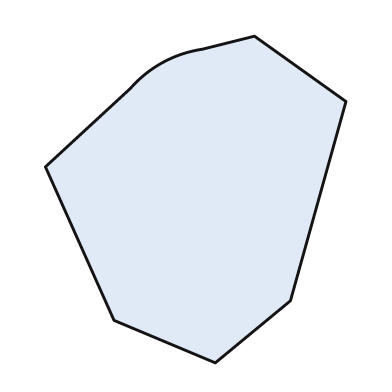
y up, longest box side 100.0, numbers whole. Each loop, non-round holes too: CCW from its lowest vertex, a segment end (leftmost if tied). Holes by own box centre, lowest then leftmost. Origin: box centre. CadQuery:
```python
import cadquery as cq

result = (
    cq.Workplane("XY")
    .moveTo(6.0, -50.0)
    .lineTo(29.0, -31.0)
    .lineTo(46.0, 30.0)
    .lineTo(18.0, 50.0)
    .lineTo(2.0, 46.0)
    .threePointArc((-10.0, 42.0), (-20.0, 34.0))
    .lineTo(-46.0, 10.0)
    .lineTo(-25.0, -37.0)
    .close()
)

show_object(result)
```